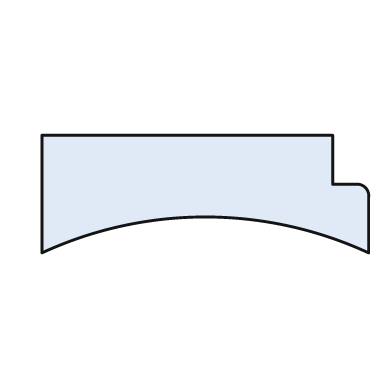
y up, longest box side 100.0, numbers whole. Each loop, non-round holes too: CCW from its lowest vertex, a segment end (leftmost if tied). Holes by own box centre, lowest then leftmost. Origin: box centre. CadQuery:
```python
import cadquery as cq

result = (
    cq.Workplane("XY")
    .moveTo(-50.0, -18.0)
    .threePointArc((0.0, -7.0), (50.0, -18.0))
    .lineTo(50.0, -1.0)
    .threePointArc((49.0, 2.0), (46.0, 3.0))
    .lineTo(39.0, 3.0)
    .lineTo(39.0, 18.0)
    .lineTo(-50.0, 18.0)
    .close()
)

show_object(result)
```